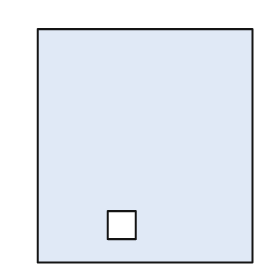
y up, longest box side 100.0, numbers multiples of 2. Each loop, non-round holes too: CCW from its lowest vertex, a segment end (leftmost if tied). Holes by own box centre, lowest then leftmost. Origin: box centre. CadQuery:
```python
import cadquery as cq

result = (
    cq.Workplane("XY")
    .moveTo(-46.0, -50.0)
    .lineTo(46.0, -50.0)
    .lineTo(46.0, 50.0)
    .lineTo(-46.0, 50.0)
    .close()
    .moveTo(-16.0, -40.0)
    .lineTo(-4.0, -40.0)
    .lineTo(-4.0, -28.0)
    .lineTo(-16.0, -28.0)
    .close()
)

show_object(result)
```